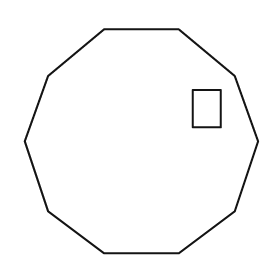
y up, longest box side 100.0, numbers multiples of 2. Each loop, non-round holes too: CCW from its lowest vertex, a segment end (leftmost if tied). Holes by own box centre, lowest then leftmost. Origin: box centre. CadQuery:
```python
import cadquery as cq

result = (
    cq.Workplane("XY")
    .moveTo(-16.0, -48.0)
    .lineTo(16.0, -48.0)
    .lineTo(40.0, -30.0)
    .lineTo(50.0, 0.0)
    .lineTo(40.0, 28.0)
    .lineTo(16.0, 48.0)
    .lineTo(-16.0, 48.0)
    .lineTo(-40.0, 28.0)
    .lineTo(-50.0, 0.0)
    .lineTo(-40.0, -30.0)
    .close()
    .moveTo(22.0, 6.0)
    .lineTo(34.0, 6.0)
    .lineTo(34.0, 22.0)
    .lineTo(22.0, 22.0)
    .close()
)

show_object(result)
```